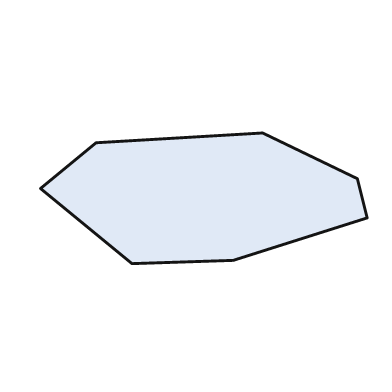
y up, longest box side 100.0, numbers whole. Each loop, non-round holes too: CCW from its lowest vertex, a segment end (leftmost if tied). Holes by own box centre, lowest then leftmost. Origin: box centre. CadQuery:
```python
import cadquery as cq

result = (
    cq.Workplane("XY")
    .moveTo(-22.0, -20.0)
    .lineTo(9.0, -19.0)
    .lineTo(50.0, -6.0)
    .lineTo(47.0, 6.0)
    .lineTo(18.0, 20.0)
    .lineTo(-33.0, 17.0)
    .lineTo(-50.0, 3.0)
    .close()
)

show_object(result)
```